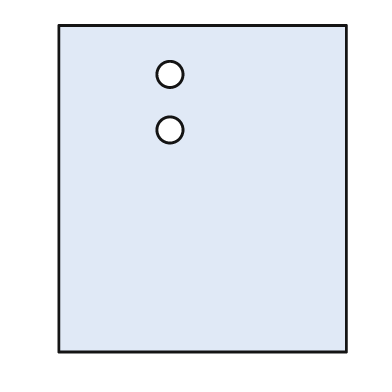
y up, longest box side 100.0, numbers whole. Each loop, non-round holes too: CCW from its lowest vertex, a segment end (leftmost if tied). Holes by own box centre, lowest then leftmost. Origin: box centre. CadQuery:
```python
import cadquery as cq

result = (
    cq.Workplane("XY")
    .moveTo(-44.0, -50.0)
    .lineTo(44.0, -50.0)
    .lineTo(44.0, 50.0)
    .lineTo(-44.0, 50.0)
    .close()
    .moveTo(-10.0, 18.0)
    .circle(4.0)
    .moveTo(-10.0, 35.0)
    .circle(4.0)
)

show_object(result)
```